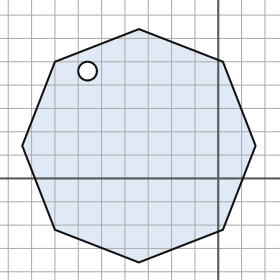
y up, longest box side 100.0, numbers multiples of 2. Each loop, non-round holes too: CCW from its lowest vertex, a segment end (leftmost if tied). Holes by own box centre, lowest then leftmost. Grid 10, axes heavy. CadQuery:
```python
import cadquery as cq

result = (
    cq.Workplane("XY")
    .moveTo(-34.0, -36.0)
    .lineTo(2.0, -22.0)
    .lineTo(16.0, 14.0)
    .lineTo(2.0, 50.0)
    .lineTo(-34.0, 64.0)
    .lineTo(-70.0, 50.0)
    .lineTo(-84.0, 14.0)
    .lineTo(-70.0, -22.0)
    .close()
    .moveTo(-56.0, 46.0)
    .circle(4.0)
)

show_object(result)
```